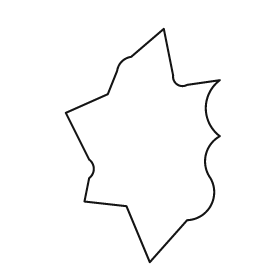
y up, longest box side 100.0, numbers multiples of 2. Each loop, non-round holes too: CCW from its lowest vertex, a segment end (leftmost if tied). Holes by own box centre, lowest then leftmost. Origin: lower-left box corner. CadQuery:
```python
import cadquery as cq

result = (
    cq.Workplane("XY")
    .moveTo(36.0, 0.0)
    .lineTo(52.0, 18.0)
    .threePointArc((62.0, 24.0), (62.0, 36.0))
    .threePointArc((60.0, 46.0), (66.0, 54.0))
    .threePointArc((60.0, 66.0), (66.0, 78.0))
    .lineTo(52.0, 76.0)
    .threePointArc((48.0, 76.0), (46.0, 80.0))
    .lineTo(42.0, 100.0)
    .lineTo(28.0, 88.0)
    .threePointArc((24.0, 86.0), (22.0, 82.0))
    .lineTo(18.0, 72.0)
    .lineTo(0.0, 64.0)
    .lineTo(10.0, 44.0)
    .threePointArc((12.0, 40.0), (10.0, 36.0))
    .lineTo(8.0, 26.0)
    .lineTo(26.0, 24.0)
    .close()
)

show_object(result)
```